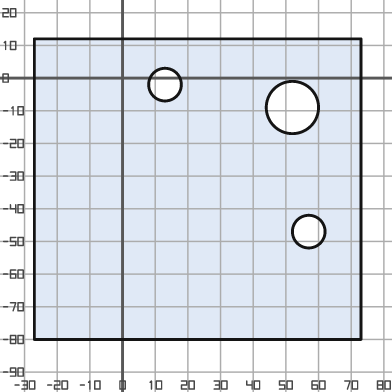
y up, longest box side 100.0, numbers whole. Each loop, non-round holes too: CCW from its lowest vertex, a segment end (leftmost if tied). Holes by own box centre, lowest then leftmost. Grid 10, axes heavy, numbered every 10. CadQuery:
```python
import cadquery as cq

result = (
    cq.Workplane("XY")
    .moveTo(-27.0, -80.0)
    .lineTo(73.0, -80.0)
    .lineTo(73.0, 12.0)
    .lineTo(-27.0, 12.0)
    .close()
    .moveTo(57.0, -47.0)
    .circle(5.0)
    .moveTo(52.0, -9.0)
    .circle(8.0)
    .moveTo(13.0, -2.0)
    .circle(5.0)
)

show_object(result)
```